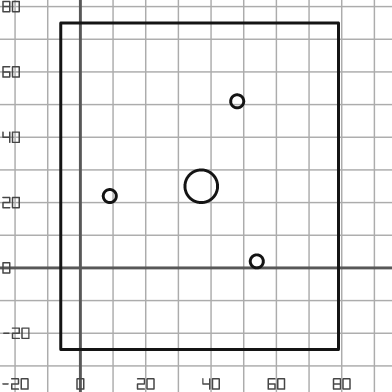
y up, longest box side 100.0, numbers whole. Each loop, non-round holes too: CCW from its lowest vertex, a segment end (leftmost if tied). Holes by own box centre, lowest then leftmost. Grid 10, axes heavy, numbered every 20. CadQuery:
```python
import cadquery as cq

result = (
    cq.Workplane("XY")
    .moveTo(-6.0, -25.0)
    .lineTo(79.0, -25.0)
    .lineTo(79.0, 75.0)
    .lineTo(-6.0, 75.0)
    .close()
    .moveTo(54.0, 2.0)
    .circle(2.0)
    .moveTo(9.0, 22.0)
    .circle(2.0)
    .moveTo(37.0, 25.0)
    .circle(5.0)
    .moveTo(48.0, 51.0)
    .circle(2.0)
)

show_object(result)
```